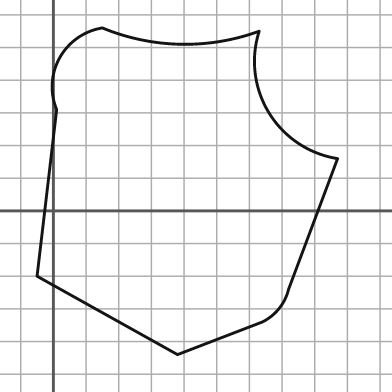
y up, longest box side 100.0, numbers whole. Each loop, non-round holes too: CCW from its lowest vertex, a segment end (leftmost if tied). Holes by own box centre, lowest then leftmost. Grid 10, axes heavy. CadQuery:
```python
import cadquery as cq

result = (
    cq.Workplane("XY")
    .moveTo(38.0, -44.0)
    .lineTo(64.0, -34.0)
    .threePointArc((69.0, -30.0), (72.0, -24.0))
    .lineTo(87.0, 16.0)
    .threePointArc((66.0, 30.0), (63.0, 55.0))
    .threePointArc((39.0, 51.0), (15.0, 56.0))
    .threePointArc((2.0, 47.0), (1.0, 31.0))
    .lineTo(-5.0, -20.0)
    .close()
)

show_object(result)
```